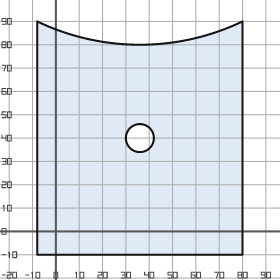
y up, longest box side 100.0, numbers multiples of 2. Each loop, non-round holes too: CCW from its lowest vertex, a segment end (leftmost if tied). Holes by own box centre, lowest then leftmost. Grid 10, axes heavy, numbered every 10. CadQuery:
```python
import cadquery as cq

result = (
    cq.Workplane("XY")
    .moveTo(-8.0, -10.0)
    .lineTo(80.0, -10.0)
    .lineTo(80.0, 90.0)
    .threePointArc((36.0, 80.0), (-8.0, 90.0))
    .close()
    .moveTo(36.0, 40.0)
    .circle(6.0)
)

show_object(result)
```